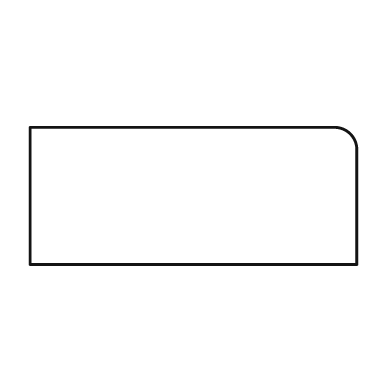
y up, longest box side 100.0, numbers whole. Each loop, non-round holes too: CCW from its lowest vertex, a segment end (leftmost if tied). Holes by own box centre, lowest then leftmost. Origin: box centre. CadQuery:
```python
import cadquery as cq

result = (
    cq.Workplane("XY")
    .moveTo(-50.0, -21.0)
    .lineTo(50.0, -21.0)
    .lineTo(50.0, 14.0)
    .threePointArc((48.0, 19.0), (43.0, 21.0))
    .lineTo(-50.0, 21.0)
    .close()
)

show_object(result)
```